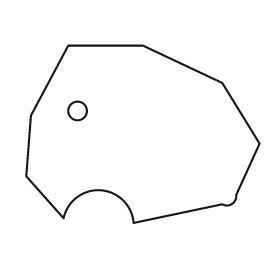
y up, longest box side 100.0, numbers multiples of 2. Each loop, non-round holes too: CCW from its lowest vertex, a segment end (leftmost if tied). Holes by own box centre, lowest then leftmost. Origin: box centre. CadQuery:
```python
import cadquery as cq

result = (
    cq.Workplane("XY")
    .moveTo(-4.0, -38.0)
    .lineTo(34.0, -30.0)
    .threePointArc((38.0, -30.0), (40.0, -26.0))
    .lineTo(50.0, -4.0)
    .lineTo(34.0, 22.0)
    .lineTo(0.0, 38.0)
    .lineTo(-32.0, 38.0)
    .lineTo(-48.0, 8.0)
    .lineTo(-50.0, -18.0)
    .lineTo(-34.0, -36.0)
    .threePointArc((-18.0, -24.0), (-4.0, -38.0))
    .close()
    .moveTo(-28.0, 10.0)
    .circle(4.0)
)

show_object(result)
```